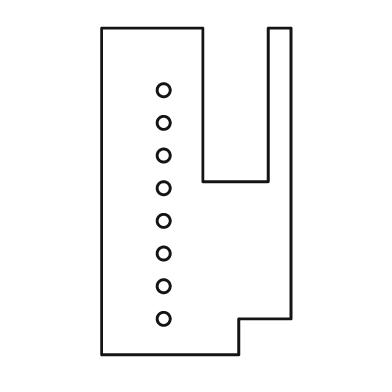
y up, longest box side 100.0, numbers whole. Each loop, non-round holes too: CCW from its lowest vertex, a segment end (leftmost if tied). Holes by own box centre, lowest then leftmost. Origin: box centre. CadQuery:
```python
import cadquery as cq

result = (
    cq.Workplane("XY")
    .moveTo(-29.0, -50.0)
    .lineTo(13.0, -50.0)
    .lineTo(13.0, -39.0)
    .lineTo(29.0, -39.0)
    .lineTo(29.0, 50.0)
    .lineTo(22.0, 50.0)
    .lineTo(22.0, 3.0)
    .lineTo(2.0, 3.0)
    .lineTo(2.0, 50.0)
    .lineTo(-29.0, 50.0)
    .close()
    .moveTo(-10.0, -39.0)
    .circle(2.0)
    .moveTo(-10.0, -29.0)
    .circle(2.0)
    .moveTo(-10.0, -19.0)
    .circle(2.0)
    .moveTo(-10.0, -9.0)
    .circle(2.0)
    .moveTo(-10.0, 1.0)
    .circle(2.0)
    .moveTo(-10.0, 11.0)
    .circle(2.0)
    .moveTo(-10.0, 21.0)
    .circle(2.0)
    .moveTo(-10.0, 31.0)
    .circle(2.0)
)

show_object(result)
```